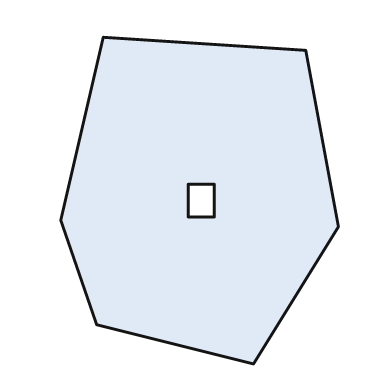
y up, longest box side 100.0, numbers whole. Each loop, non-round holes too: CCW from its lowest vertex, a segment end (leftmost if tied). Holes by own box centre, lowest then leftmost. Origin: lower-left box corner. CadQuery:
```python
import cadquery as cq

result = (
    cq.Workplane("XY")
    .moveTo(59.0, 0.0)
    .lineTo(85.0, 42.0)
    .lineTo(75.0, 96.0)
    .lineTo(13.0, 100.0)
    .lineTo(0.0, 44.0)
    .lineTo(11.0, 12.0)
    .close()
    .moveTo(39.0, 45.0)
    .lineTo(47.0, 45.0)
    .lineTo(47.0, 55.0)
    .lineTo(39.0, 55.0)
    .close()
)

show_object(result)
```